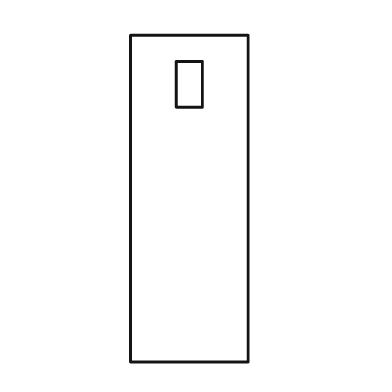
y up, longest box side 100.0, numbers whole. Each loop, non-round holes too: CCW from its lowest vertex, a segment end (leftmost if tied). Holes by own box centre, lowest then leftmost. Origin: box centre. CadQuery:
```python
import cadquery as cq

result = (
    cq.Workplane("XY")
    .moveTo(-18.0, -50.0)
    .lineTo(18.0, -50.0)
    .lineTo(18.0, 50.0)
    .lineTo(-18.0, 50.0)
    .close()
    .moveTo(-4.0, 28.0)
    .lineTo(4.0, 28.0)
    .lineTo(4.0, 42.0)
    .lineTo(-4.0, 42.0)
    .close()
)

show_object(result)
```